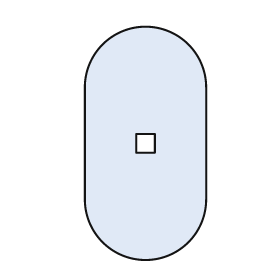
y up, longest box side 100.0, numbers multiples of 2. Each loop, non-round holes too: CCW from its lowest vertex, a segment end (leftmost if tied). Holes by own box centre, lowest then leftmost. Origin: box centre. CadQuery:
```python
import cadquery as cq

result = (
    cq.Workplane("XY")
    .moveTo(-26.0, -24.0)
    .threePointArc((0.0, -50.0), (26.0, -24.0))
    .lineTo(26.0, 24.0)
    .threePointArc((0.0, 50.0), (-26.0, 24.0))
    .close()
    .moveTo(-4.0, -4.0)
    .lineTo(4.0, -4.0)
    .lineTo(4.0, 4.0)
    .lineTo(-4.0, 4.0)
    .close()
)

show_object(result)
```